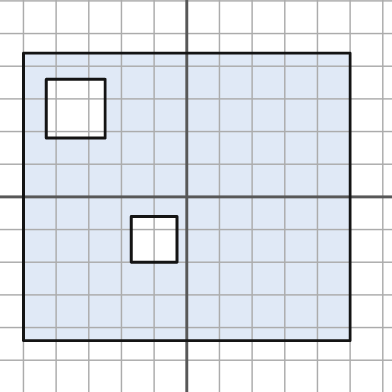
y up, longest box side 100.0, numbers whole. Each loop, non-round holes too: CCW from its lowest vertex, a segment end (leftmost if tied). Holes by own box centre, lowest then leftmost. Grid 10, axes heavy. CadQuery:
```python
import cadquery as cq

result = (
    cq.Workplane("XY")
    .moveTo(-50.0, -44.0)
    .lineTo(50.0, -44.0)
    .lineTo(50.0, 44.0)
    .lineTo(-50.0, 44.0)
    .close()
    .moveTo(-17.0, -20.0)
    .lineTo(-3.0, -20.0)
    .lineTo(-3.0, -6.0)
    .lineTo(-17.0, -6.0)
    .close()
    .moveTo(-43.0, 18.0)
    .lineTo(-25.0, 18.0)
    .lineTo(-25.0, 36.0)
    .lineTo(-43.0, 36.0)
    .close()
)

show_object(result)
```